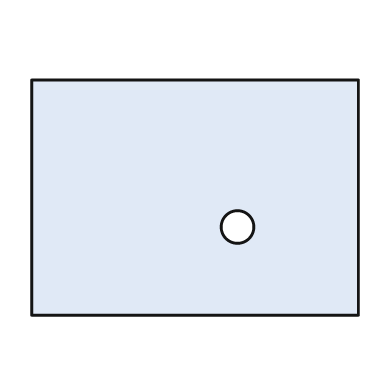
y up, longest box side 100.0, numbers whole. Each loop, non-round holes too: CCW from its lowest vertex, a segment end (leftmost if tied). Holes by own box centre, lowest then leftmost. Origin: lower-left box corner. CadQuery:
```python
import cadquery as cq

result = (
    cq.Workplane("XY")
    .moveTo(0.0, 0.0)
    .lineTo(100.0, 0.0)
    .lineTo(100.0, 72.0)
    .lineTo(0.0, 72.0)
    .close()
    .moveTo(63.0, 27.0)
    .circle(5.0)
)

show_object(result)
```